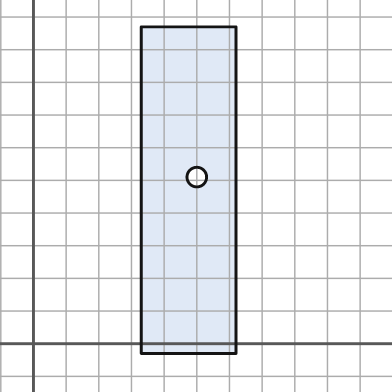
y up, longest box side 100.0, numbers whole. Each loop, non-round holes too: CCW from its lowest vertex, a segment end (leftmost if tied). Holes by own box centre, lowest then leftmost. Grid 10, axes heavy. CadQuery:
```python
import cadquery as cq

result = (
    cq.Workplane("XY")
    .moveTo(33.0, -3.0)
    .lineTo(62.0, -3.0)
    .lineTo(62.0, 97.0)
    .lineTo(33.0, 97.0)
    .close()
    .moveTo(50.0, 51.0)
    .circle(3.0)
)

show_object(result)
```